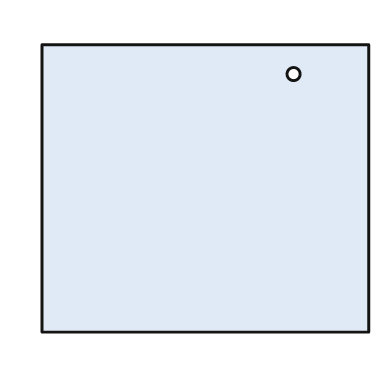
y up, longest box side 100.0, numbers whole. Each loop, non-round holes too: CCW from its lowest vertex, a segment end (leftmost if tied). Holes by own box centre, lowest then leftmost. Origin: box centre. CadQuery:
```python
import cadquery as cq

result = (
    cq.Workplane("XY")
    .moveTo(-50.0, -44.0)
    .lineTo(50.0, -44.0)
    .lineTo(50.0, 44.0)
    .lineTo(-50.0, 44.0)
    .close()
    .moveTo(27.0, 35.0)
    .circle(2.0)
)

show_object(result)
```